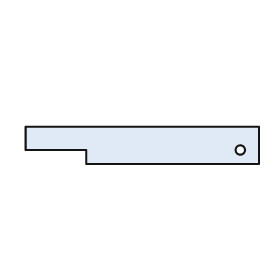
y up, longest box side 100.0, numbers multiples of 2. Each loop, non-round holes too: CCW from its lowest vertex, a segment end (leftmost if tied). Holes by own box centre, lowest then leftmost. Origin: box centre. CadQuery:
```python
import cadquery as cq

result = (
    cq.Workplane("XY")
    .moveTo(-24.0, -8.0)
    .lineTo(50.0, -8.0)
    .lineTo(50.0, 8.0)
    .lineTo(-50.0, 8.0)
    .lineTo(-50.0, -2.0)
    .lineTo(-24.0, -2.0)
    .close()
    .moveTo(42.0, -2.0)
    .circle(2.0)
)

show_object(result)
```